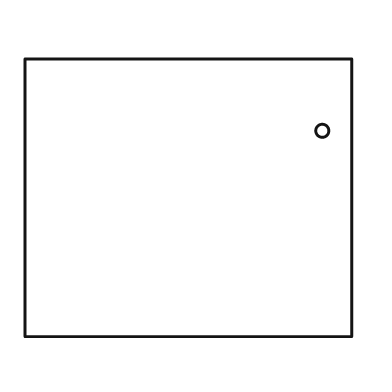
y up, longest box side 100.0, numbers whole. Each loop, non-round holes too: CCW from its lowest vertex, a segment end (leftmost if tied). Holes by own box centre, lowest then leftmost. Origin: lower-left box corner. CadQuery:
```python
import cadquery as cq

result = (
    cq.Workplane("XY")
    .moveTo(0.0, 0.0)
    .lineTo(100.0, 0.0)
    .lineTo(100.0, 85.0)
    .lineTo(0.0, 85.0)
    .close()
    .moveTo(91.0, 63.0)
    .circle(2.0)
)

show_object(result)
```